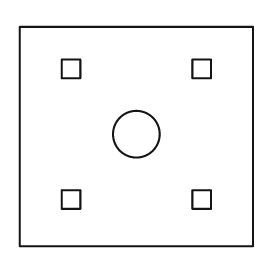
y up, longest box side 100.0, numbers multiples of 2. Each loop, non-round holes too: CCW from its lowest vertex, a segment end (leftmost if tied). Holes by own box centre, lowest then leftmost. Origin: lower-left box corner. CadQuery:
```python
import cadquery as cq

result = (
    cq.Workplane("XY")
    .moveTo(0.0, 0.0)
    .lineTo(100.0, 0.0)
    .lineTo(100.0, 94.0)
    .lineTo(0.0, 94.0)
    .close()
    .moveTo(18.0, 16.0)
    .lineTo(26.0, 16.0)
    .lineTo(26.0, 24.0)
    .lineTo(18.0, 24.0)
    .close()
    .moveTo(74.0, 16.0)
    .lineTo(82.0, 16.0)
    .lineTo(82.0, 24.0)
    .lineTo(74.0, 24.0)
    .close()
    .moveTo(50.0, 48.0)
    .circle(10.0)
    .moveTo(18.0, 72.0)
    .lineTo(26.0, 72.0)
    .lineTo(26.0, 80.0)
    .lineTo(18.0, 80.0)
    .close()
    .moveTo(74.0, 72.0)
    .lineTo(82.0, 72.0)
    .lineTo(82.0, 80.0)
    .lineTo(74.0, 80.0)
    .close()
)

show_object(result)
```